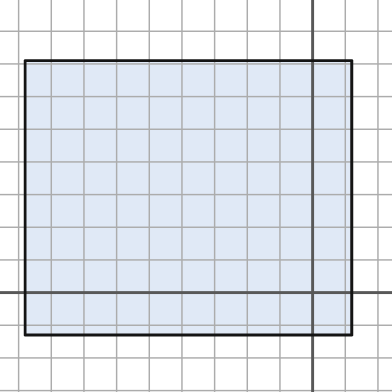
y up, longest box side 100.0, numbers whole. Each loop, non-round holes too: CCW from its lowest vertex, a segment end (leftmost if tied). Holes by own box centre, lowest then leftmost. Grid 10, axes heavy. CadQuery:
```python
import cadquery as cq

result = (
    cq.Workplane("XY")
    .moveTo(-88.0, -13.0)
    .lineTo(12.0, -13.0)
    .lineTo(12.0, 71.0)
    .lineTo(-88.0, 71.0)
    .close()
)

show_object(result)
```